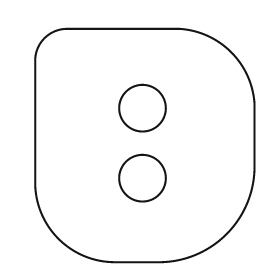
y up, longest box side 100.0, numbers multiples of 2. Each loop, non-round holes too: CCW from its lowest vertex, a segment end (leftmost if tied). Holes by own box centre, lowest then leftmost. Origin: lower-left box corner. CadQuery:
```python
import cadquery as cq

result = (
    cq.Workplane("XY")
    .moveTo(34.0, 0.0)
    .lineTo(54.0, 0.0)
    .threePointArc((82.0, 12.0), (94.0, 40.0))
    .lineTo(94.0, 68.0)
    .threePointArc((84.0, 90.0), (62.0, 100.0))
    .lineTo(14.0, 100.0)
    .threePointArc((4.0, 96.0), (0.0, 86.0))
    .lineTo(0.0, 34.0)
    .threePointArc((10.0, 10.0), (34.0, 0.0))
    .close()
    .moveTo(46.0, 36.0)
    .circle(10.0)
    .moveTo(46.0, 66.0)
    .circle(10.0)
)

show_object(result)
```